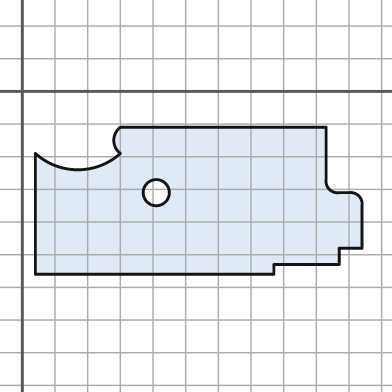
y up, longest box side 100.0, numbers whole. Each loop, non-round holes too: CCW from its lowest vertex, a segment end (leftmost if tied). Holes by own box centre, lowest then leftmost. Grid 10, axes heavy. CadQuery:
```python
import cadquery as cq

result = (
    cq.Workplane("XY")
    .moveTo(4.0, -56.0)
    .lineTo(77.0, -56.0)
    .lineTo(77.0, -53.0)
    .lineTo(97.0, -53.0)
    .lineTo(97.0, -48.0)
    .lineTo(104.0, -48.0)
    .lineTo(104.0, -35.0)
    .threePointArc((103.0, -32.0), (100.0, -31.0))
    .lineTo(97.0, -31.0)
    .threePointArc((94.0, -30.0), (93.0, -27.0))
    .lineTo(93.0, -11.0)
    .lineTo(30.0, -11.0)
    .threePointArc((28.0, -15.0), (30.0, -19.0))
    .threePointArc((17.0, -24.0), (4.0, -19.0))
    .close()
    .moveTo(41.0, -31.0)
    .circle(4.0)
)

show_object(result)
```